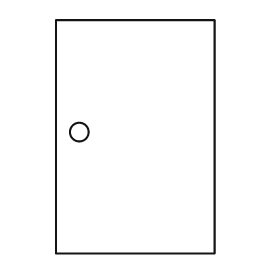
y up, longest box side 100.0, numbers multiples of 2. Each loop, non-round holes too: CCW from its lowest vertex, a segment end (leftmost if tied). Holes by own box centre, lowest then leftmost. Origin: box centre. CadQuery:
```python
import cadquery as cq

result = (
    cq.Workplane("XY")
    .moveTo(-34.0, -50.0)
    .lineTo(34.0, -50.0)
    .lineTo(34.0, 50.0)
    .lineTo(-34.0, 50.0)
    .close()
    .moveTo(-24.0, 2.0)
    .circle(4.0)
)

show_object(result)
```